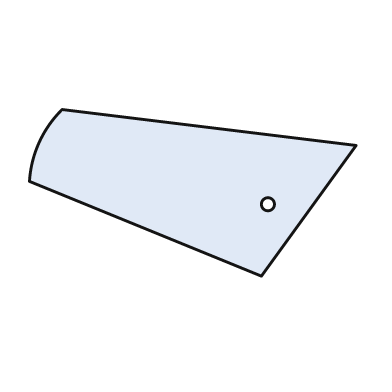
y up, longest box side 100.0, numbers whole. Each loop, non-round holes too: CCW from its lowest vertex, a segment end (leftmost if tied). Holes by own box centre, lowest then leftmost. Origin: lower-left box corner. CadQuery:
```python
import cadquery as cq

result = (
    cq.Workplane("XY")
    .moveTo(71.0, 0.0)
    .lineTo(100.0, 40.0)
    .lineTo(10.0, 51.0)
    .threePointArc((3.0, 41.0), (0.0, 29.0))
    .close()
    .moveTo(73.0, 22.0)
    .circle(2.0)
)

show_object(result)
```